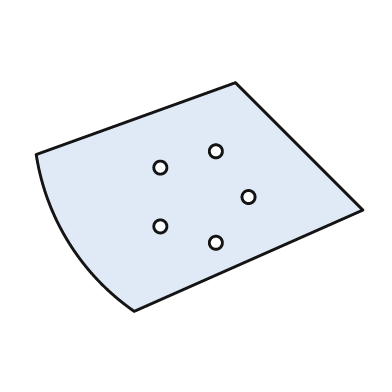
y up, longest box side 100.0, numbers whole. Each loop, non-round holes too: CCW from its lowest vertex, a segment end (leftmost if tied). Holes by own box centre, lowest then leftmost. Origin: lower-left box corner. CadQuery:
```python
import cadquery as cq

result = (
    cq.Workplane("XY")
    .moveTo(30.0, 0.0)
    .lineTo(100.0, 31.0)
    .lineTo(61.0, 70.0)
    .lineTo(0.0, 48.0)
    .threePointArc((10.0, 21.0), (30.0, 0.0))
    .close()
    .moveTo(55.0, 21.0)
    .circle(2.0)
    .moveTo(38.0, 26.0)
    .circle(2.0)
    .moveTo(65.0, 35.0)
    .circle(2.0)
    .moveTo(38.0, 44.0)
    .circle(2.0)
    .moveTo(55.0, 49.0)
    .circle(2.0)
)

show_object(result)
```